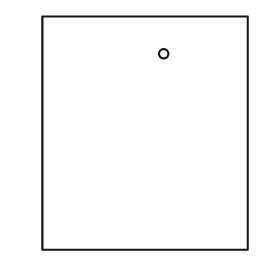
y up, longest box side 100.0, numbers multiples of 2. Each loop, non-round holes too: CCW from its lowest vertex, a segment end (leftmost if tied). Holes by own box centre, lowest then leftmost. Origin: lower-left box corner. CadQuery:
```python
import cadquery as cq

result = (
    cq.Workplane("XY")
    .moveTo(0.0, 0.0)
    .lineTo(88.0, 0.0)
    .lineTo(88.0, 100.0)
    .lineTo(0.0, 100.0)
    .close()
    .moveTo(52.0, 84.0)
    .circle(2.0)
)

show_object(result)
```